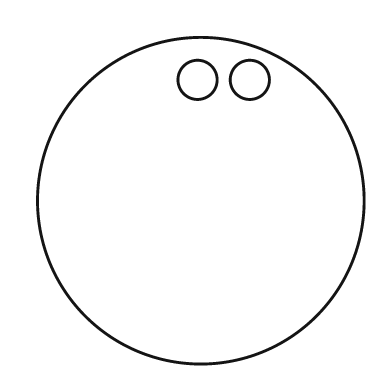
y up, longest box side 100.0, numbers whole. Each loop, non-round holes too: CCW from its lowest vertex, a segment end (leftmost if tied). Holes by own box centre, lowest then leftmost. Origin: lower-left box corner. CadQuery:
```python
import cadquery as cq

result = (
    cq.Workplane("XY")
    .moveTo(50.0, 50.0)
    .circle(50.0)
    .moveTo(49.0, 87.0)
    .circle(6.0)
    .moveTo(65.0, 87.0)
    .circle(6.0)
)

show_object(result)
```